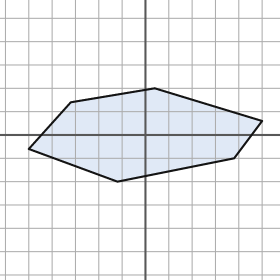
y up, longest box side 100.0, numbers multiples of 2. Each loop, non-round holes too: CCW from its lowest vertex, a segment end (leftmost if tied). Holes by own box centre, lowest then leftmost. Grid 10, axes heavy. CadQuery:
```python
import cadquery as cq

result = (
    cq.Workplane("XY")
    .moveTo(-12.0, -20.0)
    .lineTo(38.0, -10.0)
    .lineTo(50.0, 6.0)
    .lineTo(4.0, 20.0)
    .lineTo(-32.0, 14.0)
    .lineTo(-50.0, -6.0)
    .close()
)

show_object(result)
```